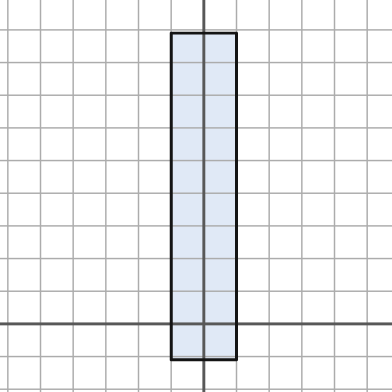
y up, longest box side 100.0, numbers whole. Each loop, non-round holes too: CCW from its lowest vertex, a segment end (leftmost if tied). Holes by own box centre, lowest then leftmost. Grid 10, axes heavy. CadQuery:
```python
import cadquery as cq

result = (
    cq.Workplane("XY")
    .moveTo(-10.0, -11.0)
    .lineTo(10.0, -11.0)
    .lineTo(10.0, 89.0)
    .lineTo(-10.0, 89.0)
    .close()
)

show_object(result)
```